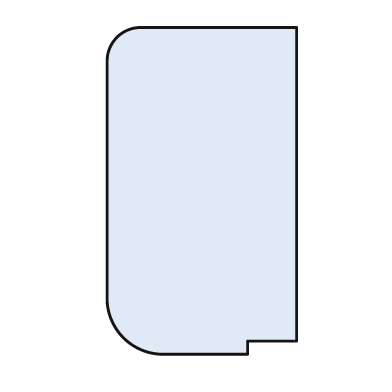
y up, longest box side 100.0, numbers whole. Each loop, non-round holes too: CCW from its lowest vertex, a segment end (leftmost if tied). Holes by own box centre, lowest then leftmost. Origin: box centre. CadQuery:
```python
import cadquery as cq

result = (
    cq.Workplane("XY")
    .moveTo(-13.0, -50.0)
    .lineTo(14.0, -50.0)
    .lineTo(14.0, -46.0)
    .lineTo(29.0, -46.0)
    .lineTo(29.0, 50.0)
    .lineTo(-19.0, 50.0)
    .threePointArc((-26.0, 47.0), (-29.0, 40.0))
    .lineTo(-29.0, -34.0)
    .threePointArc((-24.0, -45.0), (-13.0, -50.0))
    .close()
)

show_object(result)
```